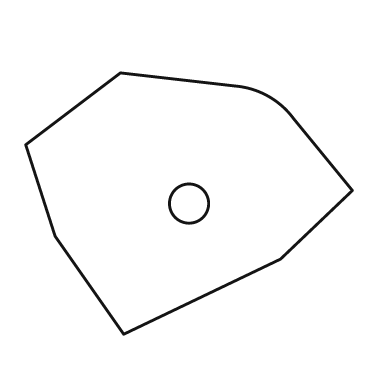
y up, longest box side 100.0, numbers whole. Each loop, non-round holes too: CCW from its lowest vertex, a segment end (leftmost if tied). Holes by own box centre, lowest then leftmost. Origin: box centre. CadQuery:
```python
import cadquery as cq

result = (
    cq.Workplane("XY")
    .moveTo(-20.0, -40.0)
    .lineTo(28.0, -17.0)
    .lineTo(50.0, 4.0)
    .lineTo(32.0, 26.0)
    .threePointArc((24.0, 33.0), (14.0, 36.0))
    .lineTo(-21.0, 40.0)
    .lineTo(-50.0, 18.0)
    .lineTo(-41.0, -10.0)
    .close()
    .moveTo(0.0, 0.0)
    .circle(6.0)
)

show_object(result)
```